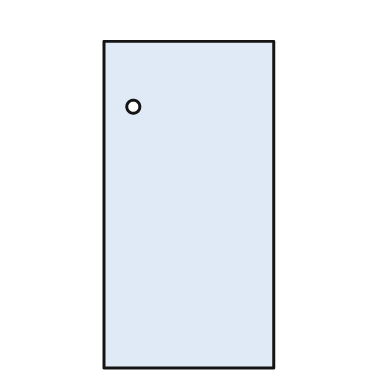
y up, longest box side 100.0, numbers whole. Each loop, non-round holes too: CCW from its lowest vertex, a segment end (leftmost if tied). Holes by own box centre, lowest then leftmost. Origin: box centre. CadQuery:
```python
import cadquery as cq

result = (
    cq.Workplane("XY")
    .moveTo(-26.0, -50.0)
    .lineTo(26.0, -50.0)
    .lineTo(26.0, 50.0)
    .lineTo(-26.0, 50.0)
    .close()
    .moveTo(-17.0, 30.0)
    .circle(2.0)
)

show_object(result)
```